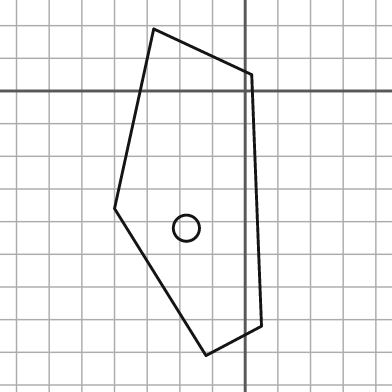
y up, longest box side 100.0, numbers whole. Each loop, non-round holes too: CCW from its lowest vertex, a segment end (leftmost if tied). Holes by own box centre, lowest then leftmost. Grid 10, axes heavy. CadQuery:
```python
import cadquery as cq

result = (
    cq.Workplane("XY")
    .moveTo(-12.0, -81.0)
    .lineTo(5.0, -72.0)
    .lineTo(2.0, 5.0)
    .lineTo(-28.0, 19.0)
    .lineTo(-40.0, -36.0)
    .close()
    .moveTo(-18.0, -42.0)
    .circle(4.0)
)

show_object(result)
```